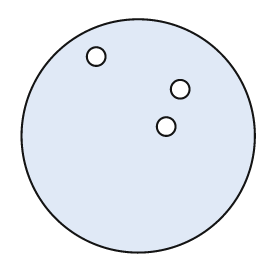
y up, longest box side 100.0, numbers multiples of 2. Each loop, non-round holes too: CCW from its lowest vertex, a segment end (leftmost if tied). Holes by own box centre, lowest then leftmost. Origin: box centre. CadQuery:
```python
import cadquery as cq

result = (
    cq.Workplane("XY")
    .moveTo(0.0, 0.0)
    .circle(50.0)
    .moveTo(12.0, 4.0)
    .circle(4.0)
    .moveTo(18.0, 20.0)
    .circle(4.0)
    .moveTo(-18.0, 34.0)
    .circle(4.0)
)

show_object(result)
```